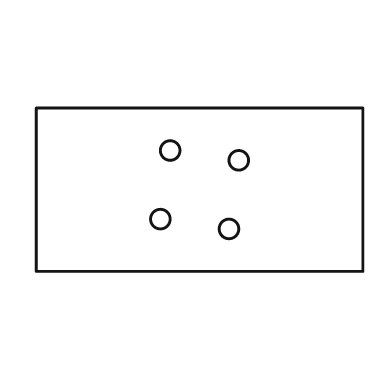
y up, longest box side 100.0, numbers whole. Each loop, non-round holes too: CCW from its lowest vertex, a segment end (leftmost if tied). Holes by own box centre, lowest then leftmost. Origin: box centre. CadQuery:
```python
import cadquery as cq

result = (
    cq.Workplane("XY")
    .moveTo(-50.0, -25.0)
    .lineTo(50.0, -25.0)
    .lineTo(50.0, 25.0)
    .lineTo(-50.0, 25.0)
    .close()
    .moveTo(9.0, -12.0)
    .circle(3.0)
    .moveTo(-12.0, -9.0)
    .circle(3.0)
    .moveTo(12.0, 9.0)
    .circle(3.0)
    .moveTo(-9.0, 12.0)
    .circle(3.0)
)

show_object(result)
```